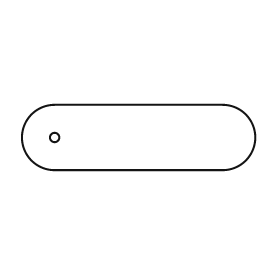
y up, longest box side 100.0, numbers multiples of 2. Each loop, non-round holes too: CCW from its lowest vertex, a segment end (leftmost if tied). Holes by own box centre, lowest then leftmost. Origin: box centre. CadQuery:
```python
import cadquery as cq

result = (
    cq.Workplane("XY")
    .moveTo(-36.0, -14.0)
    .lineTo(36.0, -14.0)
    .threePointArc((50.0, 0.0), (36.0, 14.0))
    .lineTo(-36.0, 14.0)
    .threePointArc((-50.0, 0.0), (-36.0, -14.0))
    .close()
    .moveTo(-36.0, 0.0)
    .circle(2.0)
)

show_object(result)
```